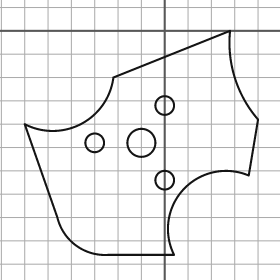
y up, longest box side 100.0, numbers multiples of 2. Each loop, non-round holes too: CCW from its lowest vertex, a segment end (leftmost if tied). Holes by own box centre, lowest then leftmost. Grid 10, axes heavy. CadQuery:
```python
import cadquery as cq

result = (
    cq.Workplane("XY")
    .moveTo(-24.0, -96.0)
    .lineTo(4.0, -96.0)
    .threePointArc((8.0, -68.0), (36.0, -62.0))
    .lineTo(40.0, -38.0)
    .threePointArc((30.0, -20.0), (28.0, 0.0))
    .lineTo(-22.0, -20.0)
    .threePointArc((-36.0, -40.0), (-60.0, -40.0))
    .lineTo(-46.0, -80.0)
    .threePointArc((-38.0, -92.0), (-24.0, -96.0))
    .close()
    .moveTo(0.0, -64.0)
    .circle(4.0)
    .moveTo(-30.0, -48.0)
    .circle(4.0)
    .moveTo(-10.0, -48.0)
    .circle(6.0)
    .moveTo(0.0, -32.0)
    .circle(4.0)
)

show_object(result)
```